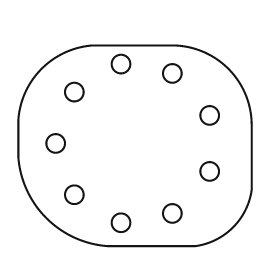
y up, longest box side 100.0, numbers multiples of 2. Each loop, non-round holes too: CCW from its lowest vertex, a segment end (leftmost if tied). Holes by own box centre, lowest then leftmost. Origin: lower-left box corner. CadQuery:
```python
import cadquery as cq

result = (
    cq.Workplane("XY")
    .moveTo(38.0, 0.0)
    .lineTo(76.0, 0.0)
    .threePointArc((92.0, 8.0), (100.0, 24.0))
    .lineTo(100.0, 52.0)
    .threePointArc((90.0, 76.0), (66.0, 86.0))
    .lineTo(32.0, 86.0)
    .threePointArc((10.0, 76.0), (0.0, 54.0))
    .lineTo(0.0, 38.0)
    .threePointArc((12.0, 12.0), (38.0, 0.0))
    .close()
    .moveTo(44.0, 10.0)
    .circle(4.0)
    .moveTo(66.0, 14.0)
    .circle(4.0)
    .moveTo(24.0, 22.0)
    .circle(4.0)
    .moveTo(82.0, 32.0)
    .circle(4.0)
    .moveTo(16.0, 44.0)
    .circle(4.0)
    .moveTo(82.0, 56.0)
    .circle(4.0)
    .moveTo(24.0, 66.0)
    .circle(4.0)
    .moveTo(66.0, 74.0)
    .circle(4.0)
    .moveTo(44.0, 78.0)
    .circle(4.0)
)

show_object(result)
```